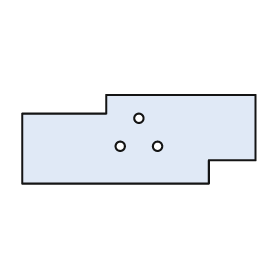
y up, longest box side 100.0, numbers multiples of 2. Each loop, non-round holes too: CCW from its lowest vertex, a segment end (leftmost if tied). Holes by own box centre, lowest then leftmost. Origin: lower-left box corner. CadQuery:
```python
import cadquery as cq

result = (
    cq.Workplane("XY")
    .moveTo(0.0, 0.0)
    .lineTo(80.0, 0.0)
    .lineTo(80.0, 10.0)
    .lineTo(100.0, 10.0)
    .lineTo(100.0, 38.0)
    .lineTo(36.0, 38.0)
    .lineTo(36.0, 30.0)
    .lineTo(0.0, 30.0)
    .close()
    .moveTo(42.0, 16.0)
    .circle(2.0)
    .moveTo(58.0, 16.0)
    .circle(2.0)
    .moveTo(50.0, 28.0)
    .circle(2.0)
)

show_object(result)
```